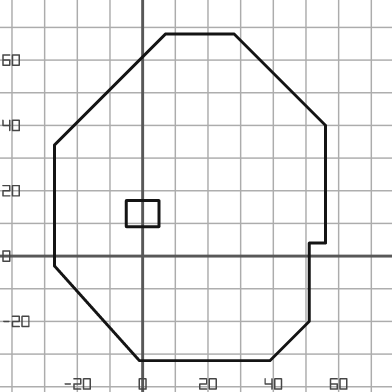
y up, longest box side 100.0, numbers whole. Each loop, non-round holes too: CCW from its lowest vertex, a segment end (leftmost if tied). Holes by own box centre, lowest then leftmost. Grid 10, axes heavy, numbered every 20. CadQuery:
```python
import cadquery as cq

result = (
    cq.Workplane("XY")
    .moveTo(-1.0, -32.0)
    .lineTo(39.0, -32.0)
    .lineTo(51.0, -20.0)
    .lineTo(51.0, 4.0)
    .lineTo(56.0, 4.0)
    .lineTo(56.0, 40.0)
    .lineTo(28.0, 68.0)
    .lineTo(7.0, 68.0)
    .lineTo(-27.0, 34.0)
    .lineTo(-27.0, -3.0)
    .close()
    .moveTo(-5.0, 9.0)
    .lineTo(5.0, 9.0)
    .lineTo(5.0, 17.0)
    .lineTo(-5.0, 17.0)
    .close()
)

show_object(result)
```